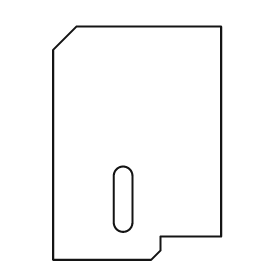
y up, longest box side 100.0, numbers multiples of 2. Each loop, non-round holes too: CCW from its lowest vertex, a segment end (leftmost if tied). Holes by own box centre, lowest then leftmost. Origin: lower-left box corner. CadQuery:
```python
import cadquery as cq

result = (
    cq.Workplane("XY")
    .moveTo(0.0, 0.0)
    .lineTo(42.0, 0.0)
    .lineTo(46.0, 4.0)
    .lineTo(46.0, 10.0)
    .lineTo(72.0, 10.0)
    .lineTo(72.0, 100.0)
    .lineTo(10.0, 100.0)
    .lineTo(0.0, 90.0)
    .close()
    .moveTo(26.0, 16.0)
    .threePointArc((30.0, 12.0), (34.0, 16.0))
    .lineTo(34.0, 36.0)
    .threePointArc((30.0, 40.0), (26.0, 36.0))
    .close()
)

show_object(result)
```